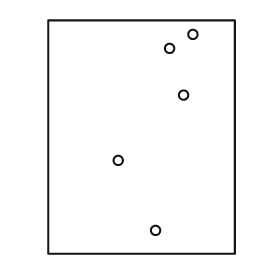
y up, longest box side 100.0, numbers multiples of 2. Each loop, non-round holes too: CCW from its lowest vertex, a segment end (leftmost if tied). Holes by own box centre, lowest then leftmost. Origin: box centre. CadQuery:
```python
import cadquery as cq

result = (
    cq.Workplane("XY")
    .moveTo(-40.0, -50.0)
    .lineTo(40.0, -50.0)
    .lineTo(40.0, 50.0)
    .lineTo(-40.0, 50.0)
    .close()
    .moveTo(6.0, -40.0)
    .circle(2.0)
    .moveTo(-10.0, -10.0)
    .circle(2.0)
    .moveTo(18.0, 18.0)
    .circle(2.0)
    .moveTo(12.0, 38.0)
    .circle(2.0)
    .moveTo(22.0, 44.0)
    .circle(2.0)
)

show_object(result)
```